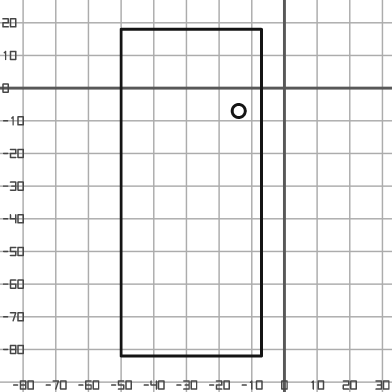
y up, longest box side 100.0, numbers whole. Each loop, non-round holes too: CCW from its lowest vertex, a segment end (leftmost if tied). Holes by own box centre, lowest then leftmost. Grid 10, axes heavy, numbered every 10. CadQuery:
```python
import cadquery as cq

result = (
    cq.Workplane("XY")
    .moveTo(-50.0, -82.0)
    .lineTo(-7.0, -82.0)
    .lineTo(-7.0, 18.0)
    .lineTo(-50.0, 18.0)
    .close()
    .moveTo(-14.0, -7.0)
    .circle(2.0)
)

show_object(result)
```